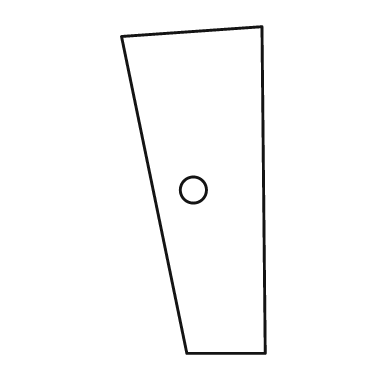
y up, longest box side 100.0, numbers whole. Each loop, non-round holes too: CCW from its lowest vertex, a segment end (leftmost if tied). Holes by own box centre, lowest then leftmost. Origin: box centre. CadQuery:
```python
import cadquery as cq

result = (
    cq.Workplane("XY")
    .moveTo(-2.0, -50.0)
    .lineTo(22.0, -50.0)
    .lineTo(21.0, 50.0)
    .lineTo(-22.0, 47.0)
    .close()
    .moveTo(0.0, 0.0)
    .circle(4.0)
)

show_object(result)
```